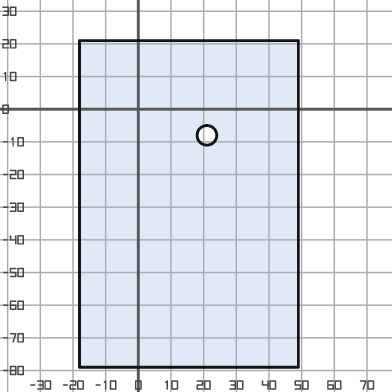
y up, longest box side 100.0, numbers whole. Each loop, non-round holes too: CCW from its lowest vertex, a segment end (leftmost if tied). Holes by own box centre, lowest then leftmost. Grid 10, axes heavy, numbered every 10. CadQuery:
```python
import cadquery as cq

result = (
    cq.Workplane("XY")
    .moveTo(-18.0, -79.0)
    .lineTo(49.0, -79.0)
    .lineTo(49.0, 21.0)
    .lineTo(-18.0, 21.0)
    .close()
    .moveTo(21.0, -8.0)
    .circle(3.0)
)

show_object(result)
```